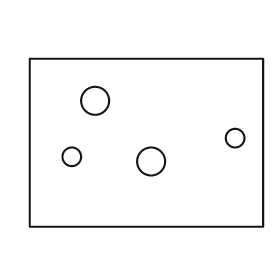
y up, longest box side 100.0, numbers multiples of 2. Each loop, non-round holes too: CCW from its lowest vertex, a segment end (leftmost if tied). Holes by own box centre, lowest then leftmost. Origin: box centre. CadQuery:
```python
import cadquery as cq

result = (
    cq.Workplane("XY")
    .moveTo(-50.0, -36.0)
    .lineTo(50.0, -36.0)
    .lineTo(50.0, 36.0)
    .lineTo(-50.0, 36.0)
    .close()
    .moveTo(2.0, -8.0)
    .circle(6.0)
    .moveTo(-32.0, -6.0)
    .circle(4.0)
    .moveTo(38.0, 2.0)
    .circle(4.0)
    .moveTo(-22.0, 18.0)
    .circle(6.0)
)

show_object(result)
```